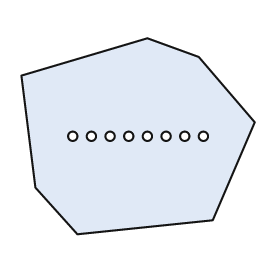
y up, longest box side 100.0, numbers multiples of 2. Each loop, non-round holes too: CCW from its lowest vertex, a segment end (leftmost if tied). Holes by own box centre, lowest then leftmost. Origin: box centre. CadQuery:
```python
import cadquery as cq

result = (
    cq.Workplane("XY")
    .moveTo(-26.0, -42.0)
    .lineTo(32.0, -36.0)
    .lineTo(50.0, 6.0)
    .lineTo(26.0, 34.0)
    .lineTo(4.0, 42.0)
    .lineTo(-50.0, 26.0)
    .lineTo(-44.0, -22.0)
    .close()
    .moveTo(-28.0, 0.0)
    .circle(2.0)
    .moveTo(-20.0, 0.0)
    .circle(2.0)
    .moveTo(-12.0, 0.0)
    .circle(2.0)
    .moveTo(-4.0, 0.0)
    .circle(2.0)
    .moveTo(4.0, 0.0)
    .circle(2.0)
    .moveTo(12.0, 0.0)
    .circle(2.0)
    .moveTo(20.0, 0.0)
    .circle(2.0)
    .moveTo(28.0, 0.0)
    .circle(2.0)
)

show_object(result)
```